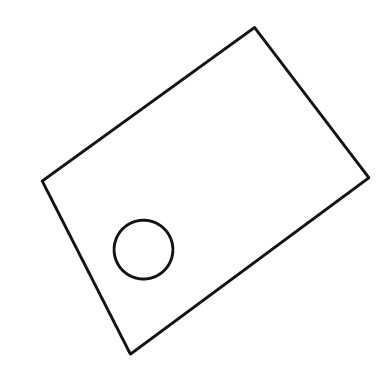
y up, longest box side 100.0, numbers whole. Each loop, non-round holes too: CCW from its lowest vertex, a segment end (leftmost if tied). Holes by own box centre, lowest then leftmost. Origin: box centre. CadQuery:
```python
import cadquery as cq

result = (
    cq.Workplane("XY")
    .moveTo(-23.0, -50.0)
    .lineTo(50.0, 4.0)
    .lineTo(15.0, 50.0)
    .lineTo(-50.0, 3.0)
    .close()
    .moveTo(-19.0, -18.0)
    .circle(9.0)
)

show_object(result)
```